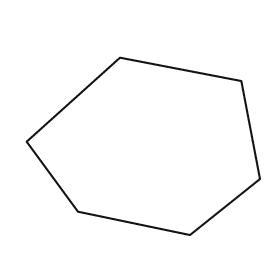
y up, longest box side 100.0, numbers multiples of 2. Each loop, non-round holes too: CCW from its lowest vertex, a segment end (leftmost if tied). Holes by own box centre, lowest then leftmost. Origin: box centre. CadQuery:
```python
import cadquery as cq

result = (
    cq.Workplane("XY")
    .moveTo(20.0, -38.0)
    .lineTo(50.0, -14.0)
    .lineTo(42.0, 28.0)
    .lineTo(-10.0, 38.0)
    .lineTo(-50.0, 2.0)
    .lineTo(-28.0, -28.0)
    .close()
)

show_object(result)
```